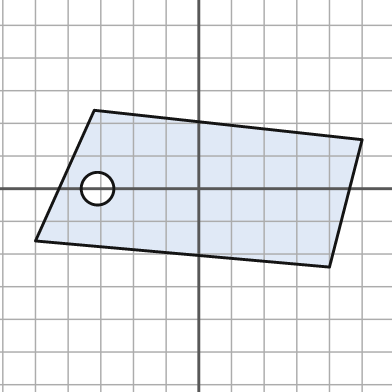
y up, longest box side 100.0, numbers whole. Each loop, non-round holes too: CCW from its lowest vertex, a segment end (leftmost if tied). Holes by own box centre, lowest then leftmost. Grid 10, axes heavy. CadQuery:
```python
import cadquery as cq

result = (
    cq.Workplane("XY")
    .moveTo(40.0, -24.0)
    .lineTo(50.0, 15.0)
    .lineTo(-32.0, 24.0)
    .lineTo(-50.0, -16.0)
    .close()
    .moveTo(-31.0, 0.0)
    .circle(5.0)
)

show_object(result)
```